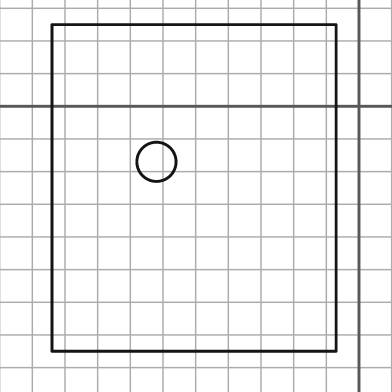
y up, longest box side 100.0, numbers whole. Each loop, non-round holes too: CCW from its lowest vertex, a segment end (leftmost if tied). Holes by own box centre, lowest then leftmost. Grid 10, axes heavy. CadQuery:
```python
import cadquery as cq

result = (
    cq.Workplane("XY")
    .moveTo(-94.0, -75.0)
    .lineTo(-7.0, -75.0)
    .lineTo(-7.0, 25.0)
    .lineTo(-94.0, 25.0)
    .close()
    .moveTo(-62.0, -17.0)
    .circle(6.0)
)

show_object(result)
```